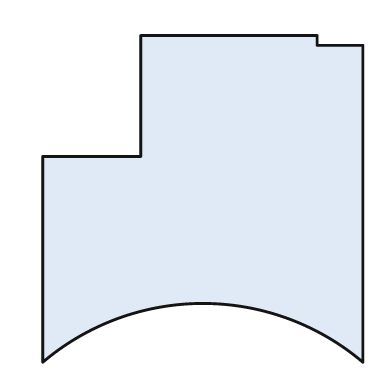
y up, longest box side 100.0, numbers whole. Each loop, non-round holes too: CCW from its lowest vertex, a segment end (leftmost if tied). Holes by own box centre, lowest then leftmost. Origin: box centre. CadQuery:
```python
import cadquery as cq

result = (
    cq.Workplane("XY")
    .moveTo(-49.0, -50.0)
    .threePointArc((0.0, -32.0), (49.0, -50.0))
    .lineTo(49.0, 47.0)
    .lineTo(35.0, 47.0)
    .lineTo(35.0, 50.0)
    .lineTo(-19.0, 50.0)
    .lineTo(-19.0, 13.0)
    .lineTo(-49.0, 13.0)
    .close()
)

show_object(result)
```